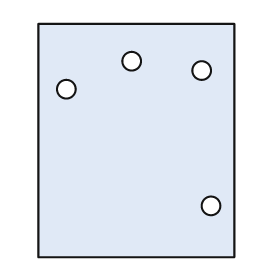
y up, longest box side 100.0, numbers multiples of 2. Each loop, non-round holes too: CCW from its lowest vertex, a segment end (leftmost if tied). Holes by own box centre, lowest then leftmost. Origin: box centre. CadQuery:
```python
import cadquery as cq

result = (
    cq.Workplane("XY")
    .moveTo(-42.0, -50.0)
    .lineTo(42.0, -50.0)
    .lineTo(42.0, 50.0)
    .lineTo(-42.0, 50.0)
    .close()
    .moveTo(32.0, -28.0)
    .circle(4.0)
    .moveTo(-30.0, 22.0)
    .circle(4.0)
    .moveTo(28.0, 30.0)
    .circle(4.0)
    .moveTo(-2.0, 34.0)
    .circle(4.0)
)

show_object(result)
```